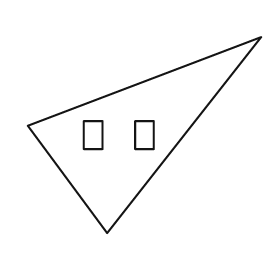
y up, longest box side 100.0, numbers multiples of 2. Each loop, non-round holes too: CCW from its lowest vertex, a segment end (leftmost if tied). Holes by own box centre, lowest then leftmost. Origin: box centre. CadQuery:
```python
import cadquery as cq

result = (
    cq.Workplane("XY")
    .moveTo(-16.0, -42.0)
    .lineTo(50.0, 42.0)
    .lineTo(-50.0, 4.0)
    .close()
    .moveTo(-26.0, -6.0)
    .lineTo(-18.0, -6.0)
    .lineTo(-18.0, 6.0)
    .lineTo(-26.0, 6.0)
    .close()
    .moveTo(-4.0, -6.0)
    .lineTo(4.0, -6.0)
    .lineTo(4.0, 6.0)
    .lineTo(-4.0, 6.0)
    .close()
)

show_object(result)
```